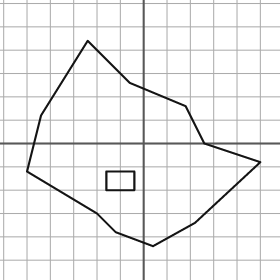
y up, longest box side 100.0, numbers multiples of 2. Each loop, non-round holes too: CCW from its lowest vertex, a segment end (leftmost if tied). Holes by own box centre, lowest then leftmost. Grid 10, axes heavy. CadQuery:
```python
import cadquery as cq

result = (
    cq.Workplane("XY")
    .moveTo(4.0, -44.0)
    .lineTo(22.0, -34.0)
    .lineTo(50.0, -8.0)
    .lineTo(26.0, 0.0)
    .lineTo(18.0, 16.0)
    .lineTo(-6.0, 26.0)
    .lineTo(-24.0, 44.0)
    .lineTo(-44.0, 12.0)
    .lineTo(-50.0, -12.0)
    .lineTo(-20.0, -30.0)
    .lineTo(-12.0, -38.0)
    .close()
    .moveTo(-16.0, -20.0)
    .lineTo(-4.0, -20.0)
    .lineTo(-4.0, -12.0)
    .lineTo(-16.0, -12.0)
    .close()
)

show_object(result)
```